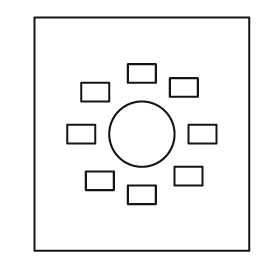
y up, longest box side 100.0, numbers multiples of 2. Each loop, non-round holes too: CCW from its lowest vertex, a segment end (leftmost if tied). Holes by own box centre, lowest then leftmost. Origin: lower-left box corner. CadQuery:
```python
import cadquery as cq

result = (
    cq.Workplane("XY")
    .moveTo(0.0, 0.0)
    .lineTo(92.0, 0.0)
    .lineTo(92.0, 100.0)
    .lineTo(0.0, 100.0)
    .close()
    .moveTo(40.0, 20.0)
    .lineTo(52.0, 20.0)
    .lineTo(52.0, 28.0)
    .lineTo(40.0, 28.0)
    .close()
    .moveTo(22.0, 26.0)
    .lineTo(34.0, 26.0)
    .lineTo(34.0, 34.0)
    .lineTo(22.0, 34.0)
    .close()
    .moveTo(60.0, 28.0)
    .lineTo(72.0, 28.0)
    .lineTo(72.0, 36.0)
    .lineTo(60.0, 36.0)
    .close()
    .moveTo(14.0, 46.0)
    .lineTo(26.0, 46.0)
    .lineTo(26.0, 54.0)
    .lineTo(14.0, 54.0)
    .close()
    .moveTo(46.0, 50.0)
    .circle(14.0)
    .moveTo(66.0, 46.0)
    .lineTo(78.0, 46.0)
    .lineTo(78.0, 54.0)
    .lineTo(66.0, 54.0)
    .close()
    .moveTo(20.0, 64.0)
    .lineTo(32.0, 64.0)
    .lineTo(32.0, 72.0)
    .lineTo(20.0, 72.0)
    .close()
    .moveTo(58.0, 66.0)
    .lineTo(70.0, 66.0)
    .lineTo(70.0, 74.0)
    .lineTo(58.0, 74.0)
    .close()
    .moveTo(40.0, 72.0)
    .lineTo(52.0, 72.0)
    .lineTo(52.0, 80.0)
    .lineTo(40.0, 80.0)
    .close()
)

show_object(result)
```